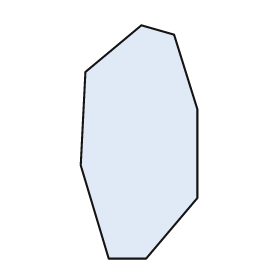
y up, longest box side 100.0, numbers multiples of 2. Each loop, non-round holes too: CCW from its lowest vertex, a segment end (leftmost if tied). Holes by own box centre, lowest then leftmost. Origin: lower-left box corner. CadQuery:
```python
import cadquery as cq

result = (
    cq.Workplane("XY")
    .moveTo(12.0, 0.0)
    .lineTo(28.0, 0.0)
    .lineTo(50.0, 26.0)
    .lineTo(50.0, 64.0)
    .lineTo(40.0, 96.0)
    .lineTo(26.0, 100.0)
    .lineTo(2.0, 80.0)
    .lineTo(0.0, 40.0)
    .close()
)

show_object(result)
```